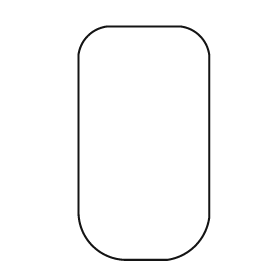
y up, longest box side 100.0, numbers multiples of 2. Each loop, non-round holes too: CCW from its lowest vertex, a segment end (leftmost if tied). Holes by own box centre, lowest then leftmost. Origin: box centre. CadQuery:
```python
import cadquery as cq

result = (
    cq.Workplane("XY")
    .moveTo(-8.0, -50.0)
    .lineTo(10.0, -50.0)
    .threePointArc((22.0, -44.0), (28.0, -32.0))
    .lineTo(28.0, 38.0)
    .threePointArc((24.0, 46.0), (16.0, 50.0))
    .lineTo(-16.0, 50.0)
    .threePointArc((-24.0, 46.0), (-28.0, 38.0))
    .lineTo(-28.0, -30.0)
    .threePointArc((-22.0, -44.0), (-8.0, -50.0))
    .close()
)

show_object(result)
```